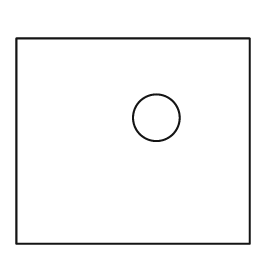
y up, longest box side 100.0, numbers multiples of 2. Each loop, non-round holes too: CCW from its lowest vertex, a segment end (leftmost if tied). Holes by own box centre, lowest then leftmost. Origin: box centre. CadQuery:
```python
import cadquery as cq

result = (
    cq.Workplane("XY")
    .moveTo(-50.0, -44.0)
    .lineTo(50.0, -44.0)
    .lineTo(50.0, 44.0)
    .lineTo(-50.0, 44.0)
    .close()
    .moveTo(10.0, 10.0)
    .circle(10.0)
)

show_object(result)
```